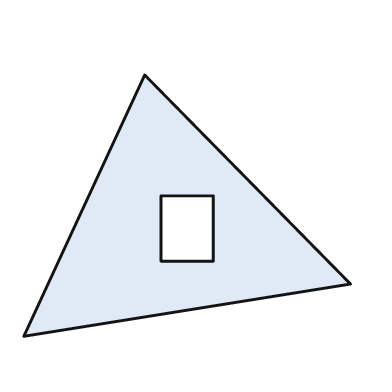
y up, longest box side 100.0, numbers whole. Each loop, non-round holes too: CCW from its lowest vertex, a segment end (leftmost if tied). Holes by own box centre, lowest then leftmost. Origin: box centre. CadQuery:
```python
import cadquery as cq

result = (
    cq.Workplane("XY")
    .moveTo(-50.0, -40.0)
    .lineTo(50.0, -24.0)
    .lineTo(-13.0, 40.0)
    .close()
    .moveTo(-8.0, -17.0)
    .lineTo(8.0, -17.0)
    .lineTo(8.0, 3.0)
    .lineTo(-8.0, 3.0)
    .close()
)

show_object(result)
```